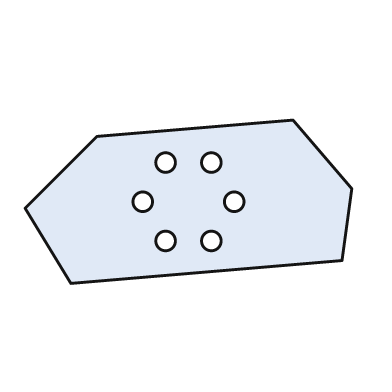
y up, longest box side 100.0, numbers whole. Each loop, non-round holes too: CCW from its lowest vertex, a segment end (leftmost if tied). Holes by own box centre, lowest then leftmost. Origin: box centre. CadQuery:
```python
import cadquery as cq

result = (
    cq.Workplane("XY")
    .moveTo(-36.0, -25.0)
    .lineTo(47.0, -18.0)
    .lineTo(50.0, 4.0)
    .lineTo(32.0, 25.0)
    .lineTo(-28.0, 20.0)
    .lineTo(-50.0, -2.0)
    .close()
    .moveTo(-7.0, -12.0)
    .circle(3.0)
    .moveTo(7.0, -12.0)
    .circle(3.0)
    .moveTo(-14.0, 0.0)
    .circle(3.0)
    .moveTo(14.0, 0.0)
    .circle(3.0)
    .moveTo(-7.0, 12.0)
    .circle(3.0)
    .moveTo(7.0, 12.0)
    .circle(3.0)
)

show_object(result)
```